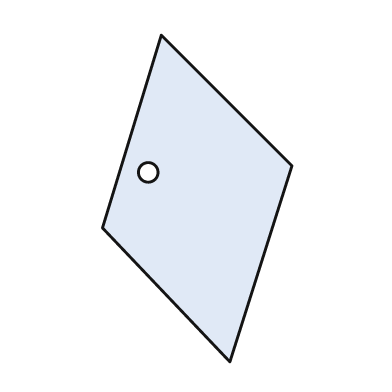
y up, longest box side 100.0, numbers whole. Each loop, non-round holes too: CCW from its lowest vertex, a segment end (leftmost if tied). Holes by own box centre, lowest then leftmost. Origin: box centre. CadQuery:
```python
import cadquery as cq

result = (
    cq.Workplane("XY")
    .moveTo(10.0, -50.0)
    .lineTo(29.0, 10.0)
    .lineTo(-11.0, 50.0)
    .lineTo(-29.0, -9.0)
    .close()
    .moveTo(-15.0, 8.0)
    .circle(3.0)
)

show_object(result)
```